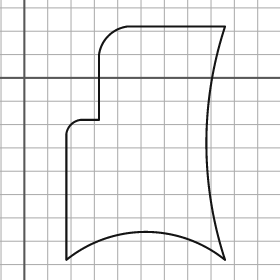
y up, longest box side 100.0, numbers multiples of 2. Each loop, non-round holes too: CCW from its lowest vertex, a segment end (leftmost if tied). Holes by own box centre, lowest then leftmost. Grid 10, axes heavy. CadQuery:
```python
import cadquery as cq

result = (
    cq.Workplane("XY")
    .moveTo(18.0, -78.0)
    .threePointArc((52.0, -66.0), (86.0, -78.0))
    .threePointArc((78.0, -28.0), (86.0, 22.0))
    .lineTo(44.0, 22.0)
    .threePointArc((36.0, 18.0), (32.0, 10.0))
    .lineTo(32.0, -18.0)
    .lineTo(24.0, -18.0)
    .threePointArc((20.0, -20.0), (18.0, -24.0))
    .close()
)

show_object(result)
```